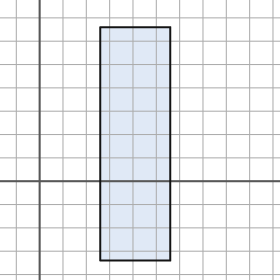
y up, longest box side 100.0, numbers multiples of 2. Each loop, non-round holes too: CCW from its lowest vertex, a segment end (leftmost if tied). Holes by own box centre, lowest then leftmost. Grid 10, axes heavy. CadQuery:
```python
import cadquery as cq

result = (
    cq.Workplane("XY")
    .moveTo(26.0, -34.0)
    .lineTo(56.0, -34.0)
    .lineTo(56.0, 66.0)
    .lineTo(26.0, 66.0)
    .close()
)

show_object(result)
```